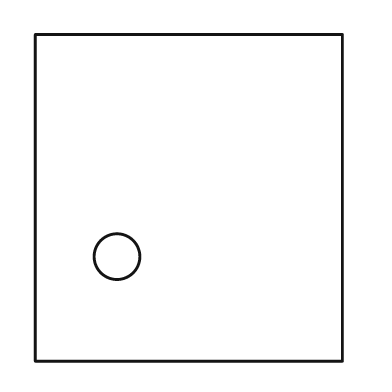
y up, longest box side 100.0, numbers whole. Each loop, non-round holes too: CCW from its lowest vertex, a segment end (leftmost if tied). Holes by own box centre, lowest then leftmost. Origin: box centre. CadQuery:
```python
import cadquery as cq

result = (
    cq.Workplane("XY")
    .moveTo(-47.0, -50.0)
    .lineTo(47.0, -50.0)
    .lineTo(47.0, 50.0)
    .lineTo(-47.0, 50.0)
    .close()
    .moveTo(-22.0, -18.0)
    .circle(7.0)
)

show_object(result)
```